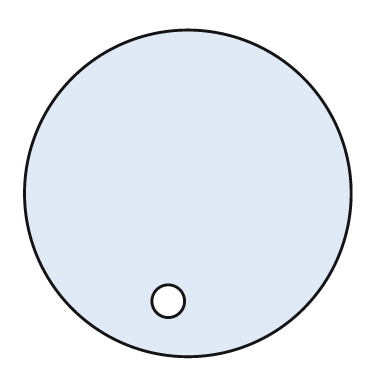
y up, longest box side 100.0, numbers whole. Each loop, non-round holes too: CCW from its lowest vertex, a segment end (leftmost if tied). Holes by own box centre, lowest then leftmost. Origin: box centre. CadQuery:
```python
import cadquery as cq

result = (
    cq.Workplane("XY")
    .moveTo(0.0, 0.0)
    .circle(50.0)
    .moveTo(-6.0, -33.0)
    .circle(5.0)
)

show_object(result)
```